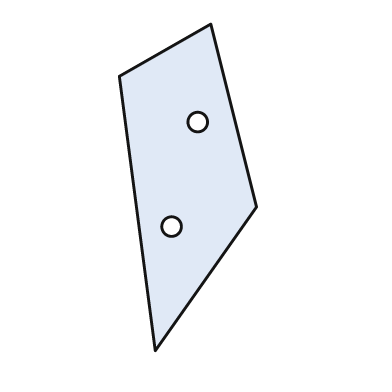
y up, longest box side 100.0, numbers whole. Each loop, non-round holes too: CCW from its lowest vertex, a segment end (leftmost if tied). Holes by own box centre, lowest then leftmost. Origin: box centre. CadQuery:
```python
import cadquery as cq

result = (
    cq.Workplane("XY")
    .moveTo(-10.0, -50.0)
    .lineTo(21.0, -6.0)
    .lineTo(7.0, 50.0)
    .lineTo(-21.0, 34.0)
    .close()
    .moveTo(-5.0, -12.0)
    .circle(3.0)
    .moveTo(3.0, 20.0)
    .circle(3.0)
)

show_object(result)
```